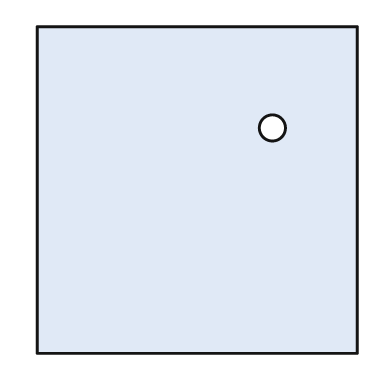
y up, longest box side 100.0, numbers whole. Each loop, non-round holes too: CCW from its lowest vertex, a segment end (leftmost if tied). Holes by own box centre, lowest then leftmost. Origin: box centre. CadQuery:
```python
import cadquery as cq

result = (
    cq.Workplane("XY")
    .moveTo(-49.0, -50.0)
    .lineTo(49.0, -50.0)
    .lineTo(49.0, 50.0)
    .lineTo(-49.0, 50.0)
    .close()
    .moveTo(23.0, 19.0)
    .circle(4.0)
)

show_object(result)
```